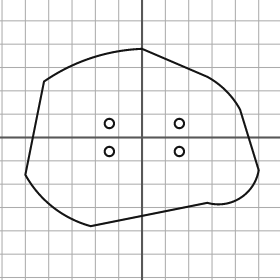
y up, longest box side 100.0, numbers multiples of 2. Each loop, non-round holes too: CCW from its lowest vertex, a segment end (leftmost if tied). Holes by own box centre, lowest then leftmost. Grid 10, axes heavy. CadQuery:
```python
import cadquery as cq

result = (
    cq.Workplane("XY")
    .moveTo(-22.0, -38.0)
    .lineTo(28.0, -28.0)
    .threePointArc((42.0, -26.0), (50.0, -14.0))
    .lineTo(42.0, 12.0)
    .threePointArc((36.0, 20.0), (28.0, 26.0))
    .lineTo(0.0, 38.0)
    .threePointArc((-22.0, 34.0), (-42.0, 24.0))
    .lineTo(-50.0, -16.0)
    .threePointArc((-38.0, -30.0), (-22.0, -38.0))
    .close()
    .moveTo(-14.0, -6.0)
    .circle(2.0)
    .moveTo(16.0, -6.0)
    .circle(2.0)
    .moveTo(-14.0, 6.0)
    .circle(2.0)
    .moveTo(16.0, 6.0)
    .circle(2.0)
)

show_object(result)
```